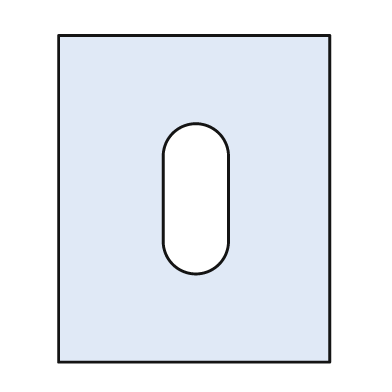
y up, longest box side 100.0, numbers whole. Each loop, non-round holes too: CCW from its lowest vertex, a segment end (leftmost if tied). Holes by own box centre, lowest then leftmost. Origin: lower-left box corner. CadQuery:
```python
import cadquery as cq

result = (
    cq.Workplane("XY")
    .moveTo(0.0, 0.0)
    .lineTo(83.0, 0.0)
    .lineTo(83.0, 100.0)
    .lineTo(0.0, 100.0)
    .close()
    .moveTo(32.0, 37.0)
    .threePointArc((42.0, 27.0), (52.0, 37.0))
    .lineTo(52.0, 63.0)
    .threePointArc((42.0, 73.0), (32.0, 63.0))
    .close()
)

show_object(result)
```